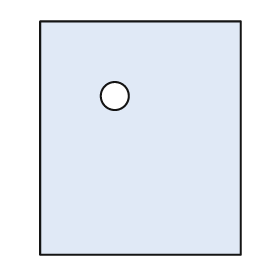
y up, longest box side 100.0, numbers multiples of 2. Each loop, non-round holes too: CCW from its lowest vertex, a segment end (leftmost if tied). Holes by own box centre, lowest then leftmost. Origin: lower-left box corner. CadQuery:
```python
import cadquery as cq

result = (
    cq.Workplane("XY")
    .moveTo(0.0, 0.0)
    .lineTo(86.0, 0.0)
    .lineTo(86.0, 100.0)
    .lineTo(0.0, 100.0)
    .close()
    .moveTo(32.0, 68.0)
    .circle(6.0)
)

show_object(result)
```